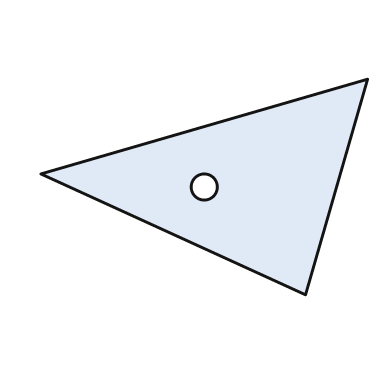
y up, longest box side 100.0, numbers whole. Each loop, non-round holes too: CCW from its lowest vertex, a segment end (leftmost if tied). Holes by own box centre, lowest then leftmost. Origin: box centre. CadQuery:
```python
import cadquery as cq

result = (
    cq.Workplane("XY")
    .moveTo(31.0, -33.0)
    .lineTo(50.0, 33.0)
    .lineTo(-50.0, 4.0)
    .close()
    .moveTo(0.0, 0.0)
    .circle(4.0)
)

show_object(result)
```